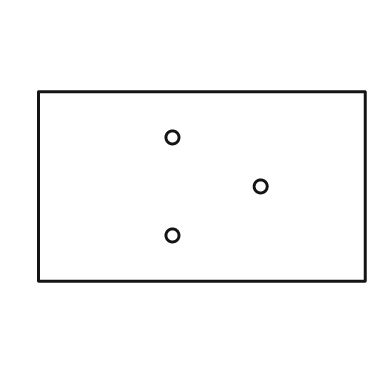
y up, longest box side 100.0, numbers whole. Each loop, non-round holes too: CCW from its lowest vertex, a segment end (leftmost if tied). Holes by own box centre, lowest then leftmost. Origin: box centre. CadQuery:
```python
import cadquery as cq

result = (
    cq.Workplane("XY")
    .moveTo(-50.0, -29.0)
    .lineTo(50.0, -29.0)
    .lineTo(50.0, 29.0)
    .lineTo(-50.0, 29.0)
    .close()
    .moveTo(-9.0, -15.0)
    .circle(2.0)
    .moveTo(18.0, 0.0)
    .circle(2.0)
    .moveTo(-9.0, 15.0)
    .circle(2.0)
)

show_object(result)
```